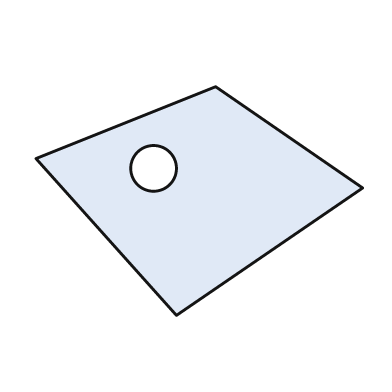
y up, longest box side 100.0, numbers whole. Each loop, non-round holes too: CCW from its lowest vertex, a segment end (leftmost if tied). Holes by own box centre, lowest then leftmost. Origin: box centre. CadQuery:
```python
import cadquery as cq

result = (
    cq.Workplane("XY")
    .moveTo(-7.0, -35.0)
    .lineTo(50.0, 4.0)
    .lineTo(5.0, 35.0)
    .lineTo(-50.0, 13.0)
    .close()
    .moveTo(-14.0, 10.0)
    .circle(7.0)
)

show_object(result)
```